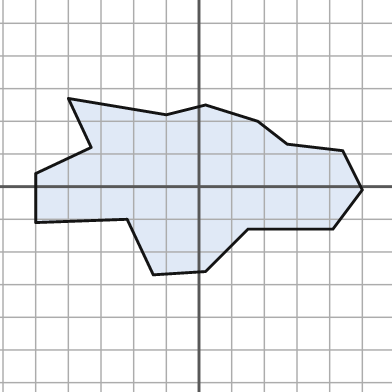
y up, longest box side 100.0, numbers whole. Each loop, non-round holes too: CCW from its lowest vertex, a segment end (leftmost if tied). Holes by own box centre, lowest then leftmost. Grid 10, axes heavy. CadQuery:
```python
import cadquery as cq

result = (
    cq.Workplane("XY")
    .moveTo(-14.0, -27.0)
    .lineTo(2.0, -26.0)
    .lineTo(15.0, -13.0)
    .lineTo(41.0, -13.0)
    .lineTo(50.0, -1.0)
    .lineTo(44.0, 11.0)
    .lineTo(27.0, 13.0)
    .lineTo(18.0, 20.0)
    .lineTo(2.0, 25.0)
    .lineTo(-10.0, 22.0)
    .lineTo(-40.0, 27.0)
    .lineTo(-33.0, 12.0)
    .lineTo(-50.0, 4.0)
    .lineTo(-50.0, -11.0)
    .lineTo(-22.0, -10.0)
    .close()
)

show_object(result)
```